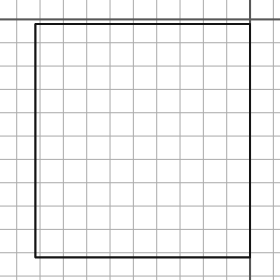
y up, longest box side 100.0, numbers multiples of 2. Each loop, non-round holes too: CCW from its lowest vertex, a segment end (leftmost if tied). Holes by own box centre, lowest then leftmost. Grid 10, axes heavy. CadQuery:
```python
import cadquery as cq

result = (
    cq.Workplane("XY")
    .moveTo(-92.0, -102.0)
    .lineTo(0.0, -102.0)
    .lineTo(0.0, -2.0)
    .lineTo(-92.0, -2.0)
    .close()
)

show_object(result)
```